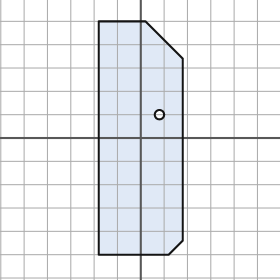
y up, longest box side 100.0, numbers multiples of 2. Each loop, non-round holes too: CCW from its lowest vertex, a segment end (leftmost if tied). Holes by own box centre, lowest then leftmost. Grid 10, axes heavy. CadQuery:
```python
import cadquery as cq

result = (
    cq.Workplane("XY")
    .moveTo(-18.0, -50.0)
    .lineTo(12.0, -50.0)
    .lineTo(18.0, -44.0)
    .lineTo(18.0, 34.0)
    .lineTo(2.0, 50.0)
    .lineTo(-18.0, 50.0)
    .close()
    .moveTo(8.0, 10.0)
    .circle(2.0)
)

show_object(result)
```